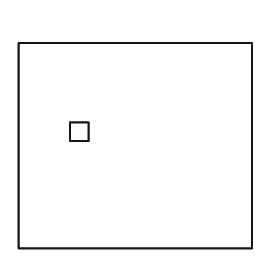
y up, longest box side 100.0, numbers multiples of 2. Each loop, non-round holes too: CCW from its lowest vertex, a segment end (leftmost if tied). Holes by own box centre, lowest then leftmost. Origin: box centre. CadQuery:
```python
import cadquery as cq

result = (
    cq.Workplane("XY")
    .moveTo(-50.0, -44.0)
    .lineTo(50.0, -44.0)
    .lineTo(50.0, 44.0)
    .lineTo(-50.0, 44.0)
    .close()
    .moveTo(-28.0, 2.0)
    .lineTo(-20.0, 2.0)
    .lineTo(-20.0, 10.0)
    .lineTo(-28.0, 10.0)
    .close()
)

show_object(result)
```